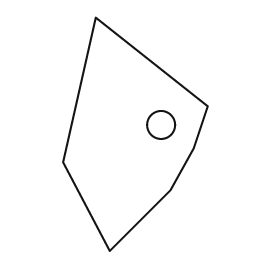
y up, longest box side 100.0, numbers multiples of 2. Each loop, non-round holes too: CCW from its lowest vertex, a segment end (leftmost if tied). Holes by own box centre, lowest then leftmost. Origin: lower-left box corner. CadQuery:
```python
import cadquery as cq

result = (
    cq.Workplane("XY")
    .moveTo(20.0, 0.0)
    .lineTo(46.0, 26.0)
    .lineTo(56.0, 44.0)
    .lineTo(62.0, 62.0)
    .lineTo(14.0, 100.0)
    .lineTo(0.0, 38.0)
    .close()
    .moveTo(42.0, 54.0)
    .circle(6.0)
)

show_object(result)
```